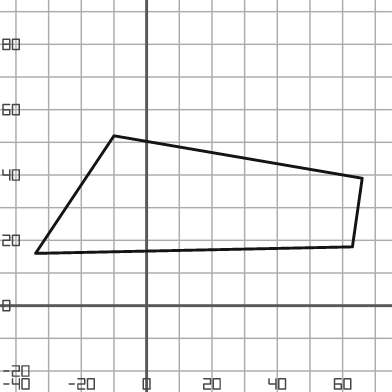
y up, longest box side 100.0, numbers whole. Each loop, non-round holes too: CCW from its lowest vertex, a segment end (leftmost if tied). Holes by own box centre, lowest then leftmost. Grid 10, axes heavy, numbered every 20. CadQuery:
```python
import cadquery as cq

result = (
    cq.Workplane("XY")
    .moveTo(-34.0, 16.0)
    .lineTo(63.0, 18.0)
    .lineTo(66.0, 39.0)
    .lineTo(-10.0, 52.0)
    .close()
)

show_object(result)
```